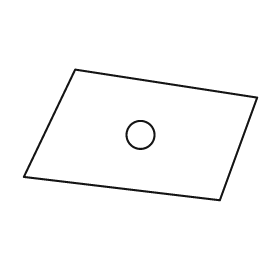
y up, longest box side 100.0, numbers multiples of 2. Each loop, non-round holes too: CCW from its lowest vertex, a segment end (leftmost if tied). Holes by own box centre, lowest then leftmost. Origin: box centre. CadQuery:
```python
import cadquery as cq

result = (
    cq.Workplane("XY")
    .moveTo(34.0, -28.0)
    .lineTo(50.0, 16.0)
    .lineTo(-28.0, 28.0)
    .lineTo(-50.0, -18.0)
    .close()
    .moveTo(0.0, 0.0)
    .circle(6.0)
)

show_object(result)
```